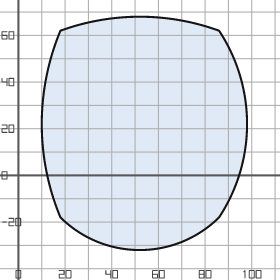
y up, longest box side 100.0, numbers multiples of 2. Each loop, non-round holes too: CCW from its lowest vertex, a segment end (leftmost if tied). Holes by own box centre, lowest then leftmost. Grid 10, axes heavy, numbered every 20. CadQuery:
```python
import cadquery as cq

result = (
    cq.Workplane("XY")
    .moveTo(18.0, -18.0)
    .threePointArc((52.0, -32.0), (86.0, -18.0))
    .threePointArc((98.0, 22.0), (86.0, 62.0))
    .threePointArc((52.0, 68.0), (18.0, 62.0))
    .threePointArc((10.0, 22.0), (18.0, -18.0))
    .close()
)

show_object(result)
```